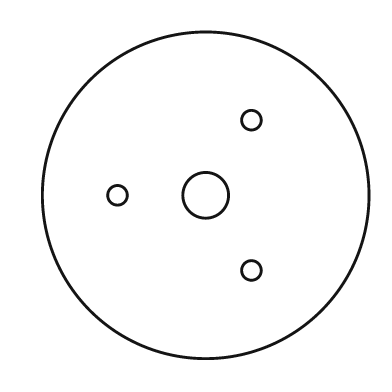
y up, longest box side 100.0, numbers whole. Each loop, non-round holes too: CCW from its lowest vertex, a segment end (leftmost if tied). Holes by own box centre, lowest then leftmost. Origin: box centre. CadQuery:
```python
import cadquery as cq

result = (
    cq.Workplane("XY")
    .moveTo(0.0, 0.0)
    .circle(50.0)
    .moveTo(14.0, -23.0)
    .circle(3.0)
    .moveTo(-27.0, 0.0)
    .circle(3.0)
    .moveTo(0.0, 0.0)
    .circle(7.0)
    .moveTo(14.0, 23.0)
    .circle(3.0)
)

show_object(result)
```